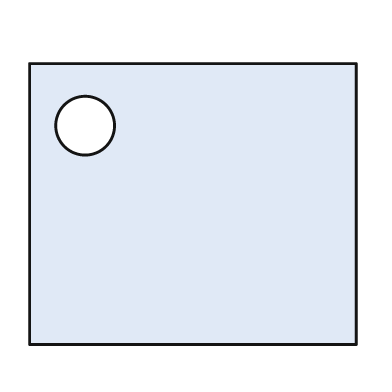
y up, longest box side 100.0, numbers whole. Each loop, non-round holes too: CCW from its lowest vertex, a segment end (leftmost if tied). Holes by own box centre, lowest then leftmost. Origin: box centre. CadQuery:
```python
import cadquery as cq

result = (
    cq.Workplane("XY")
    .moveTo(-50.0, -43.0)
    .lineTo(50.0, -43.0)
    .lineTo(50.0, 43.0)
    .lineTo(-50.0, 43.0)
    .close()
    .moveTo(-33.0, 24.0)
    .circle(9.0)
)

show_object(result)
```